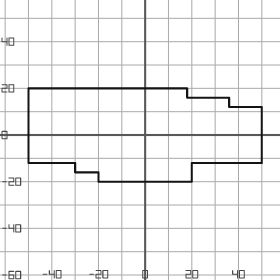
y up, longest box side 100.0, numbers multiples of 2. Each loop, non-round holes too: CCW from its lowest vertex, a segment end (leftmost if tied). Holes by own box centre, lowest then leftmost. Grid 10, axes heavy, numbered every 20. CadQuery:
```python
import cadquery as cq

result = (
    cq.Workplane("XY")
    .moveTo(-20.0, -20.0)
    .lineTo(20.0, -20.0)
    .lineTo(20.0, -12.0)
    .lineTo(50.0, -12.0)
    .lineTo(50.0, 12.0)
    .lineTo(36.0, 12.0)
    .lineTo(36.0, 16.0)
    .lineTo(18.0, 16.0)
    .lineTo(18.0, 20.0)
    .lineTo(-50.0, 20.0)
    .lineTo(-50.0, -12.0)
    .lineTo(-30.0, -12.0)
    .lineTo(-30.0, -16.0)
    .lineTo(-20.0, -16.0)
    .close()
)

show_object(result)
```